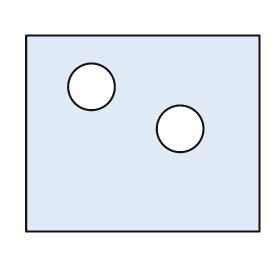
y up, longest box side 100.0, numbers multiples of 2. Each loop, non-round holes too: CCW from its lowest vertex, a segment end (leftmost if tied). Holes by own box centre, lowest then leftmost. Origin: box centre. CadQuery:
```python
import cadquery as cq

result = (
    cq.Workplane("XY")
    .moveTo(-50.0, -42.0)
    .lineTo(50.0, -42.0)
    .lineTo(50.0, 42.0)
    .lineTo(-50.0, 42.0)
    .close()
    .moveTo(16.0, 2.0)
    .circle(10.0)
    .moveTo(-22.0, 20.0)
    .circle(10.0)
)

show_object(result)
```